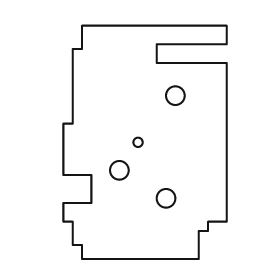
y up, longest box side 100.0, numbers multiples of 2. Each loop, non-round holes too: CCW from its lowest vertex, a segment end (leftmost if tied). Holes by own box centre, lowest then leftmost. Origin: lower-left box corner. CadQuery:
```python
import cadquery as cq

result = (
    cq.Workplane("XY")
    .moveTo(8.0, 0.0)
    .lineTo(58.0, 0.0)
    .lineTo(58.0, 12.0)
    .lineTo(62.0, 12.0)
    .lineTo(62.0, 16.0)
    .lineTo(70.0, 16.0)
    .lineTo(70.0, 84.0)
    .lineTo(40.0, 84.0)
    .lineTo(40.0, 92.0)
    .lineTo(70.0, 92.0)
    .lineTo(70.0, 100.0)
    .lineTo(8.0, 100.0)
    .lineTo(8.0, 90.0)
    .lineTo(4.0, 90.0)
    .lineTo(4.0, 58.0)
    .lineTo(0.0, 58.0)
    .lineTo(0.0, 36.0)
    .lineTo(12.0, 36.0)
    .lineTo(12.0, 24.0)
    .lineTo(0.0, 24.0)
    .lineTo(0.0, 16.0)
    .lineTo(4.0, 16.0)
    .lineTo(4.0, 6.0)
    .lineTo(8.0, 6.0)
    .close()
    .moveTo(44.0, 26.0)
    .circle(4.0)
    .moveTo(24.0, 38.0)
    .circle(4.0)
    .moveTo(32.0, 50.0)
    .circle(2.0)
    .moveTo(48.0, 70.0)
    .circle(4.0)
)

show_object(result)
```